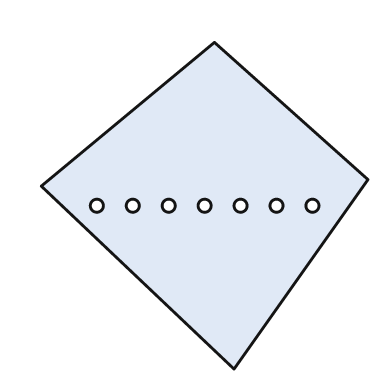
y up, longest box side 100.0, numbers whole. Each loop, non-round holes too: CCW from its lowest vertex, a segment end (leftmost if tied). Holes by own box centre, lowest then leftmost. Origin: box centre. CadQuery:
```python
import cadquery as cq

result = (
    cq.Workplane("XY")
    .moveTo(9.0, -50.0)
    .lineTo(50.0, 8.0)
    .lineTo(3.0, 50.0)
    .lineTo(-50.0, 6.0)
    .close()
    .moveTo(-33.0, 0.0)
    .circle(2.0)
    .moveTo(-22.0, 0.0)
    .circle(2.0)
    .moveTo(-11.0, 0.0)
    .circle(2.0)
    .moveTo(0.0, 0.0)
    .circle(2.0)
    .moveTo(11.0, 0.0)
    .circle(2.0)
    .moveTo(22.0, 0.0)
    .circle(2.0)
    .moveTo(33.0, 0.0)
    .circle(2.0)
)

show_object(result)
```